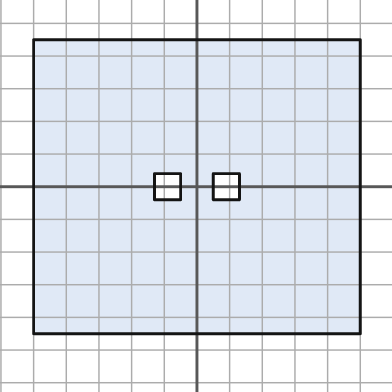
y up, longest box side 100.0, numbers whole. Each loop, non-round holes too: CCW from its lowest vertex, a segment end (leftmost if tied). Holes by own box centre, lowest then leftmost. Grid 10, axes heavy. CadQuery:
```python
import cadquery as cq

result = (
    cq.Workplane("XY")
    .moveTo(-50.0, -45.0)
    .lineTo(50.0, -45.0)
    .lineTo(50.0, 45.0)
    .lineTo(-50.0, 45.0)
    .close()
    .moveTo(-13.0, -4.0)
    .lineTo(-5.0, -4.0)
    .lineTo(-5.0, 4.0)
    .lineTo(-13.0, 4.0)
    .close()
    .moveTo(5.0, -4.0)
    .lineTo(13.0, -4.0)
    .lineTo(13.0, 4.0)
    .lineTo(5.0, 4.0)
    .close()
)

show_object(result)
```